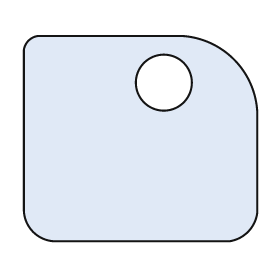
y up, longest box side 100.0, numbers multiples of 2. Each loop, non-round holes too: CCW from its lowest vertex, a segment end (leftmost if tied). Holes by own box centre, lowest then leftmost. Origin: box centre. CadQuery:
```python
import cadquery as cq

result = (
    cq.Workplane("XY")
    .moveTo(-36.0, -44.0)
    .lineTo(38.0, -44.0)
    .threePointArc((46.0, -40.0), (50.0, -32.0))
    .lineTo(50.0, 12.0)
    .threePointArc((40.0, 34.0), (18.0, 44.0))
    .lineTo(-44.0, 44.0)
    .threePointArc((-48.0, 42.0), (-50.0, 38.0))
    .lineTo(-50.0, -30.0)
    .threePointArc((-46.0, -40.0), (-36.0, -44.0))
    .close()
    .moveTo(10.0, 24.0)
    .circle(12.0)
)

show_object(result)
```